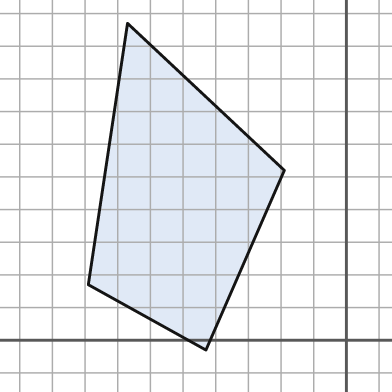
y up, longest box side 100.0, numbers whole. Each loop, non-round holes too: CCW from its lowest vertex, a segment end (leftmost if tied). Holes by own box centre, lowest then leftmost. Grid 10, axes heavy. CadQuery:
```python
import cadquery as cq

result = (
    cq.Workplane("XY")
    .moveTo(-43.0, -3.0)
    .lineTo(-19.0, 52.0)
    .lineTo(-67.0, 97.0)
    .lineTo(-79.0, 17.0)
    .close()
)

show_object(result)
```